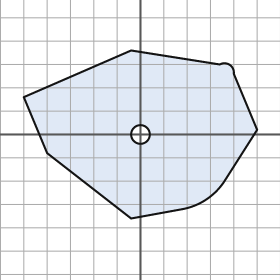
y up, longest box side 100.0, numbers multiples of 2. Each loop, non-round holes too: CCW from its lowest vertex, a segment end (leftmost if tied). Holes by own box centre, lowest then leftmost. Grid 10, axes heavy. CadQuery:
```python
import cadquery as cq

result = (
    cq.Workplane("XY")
    .moveTo(-4.0, -36.0)
    .lineTo(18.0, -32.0)
    .threePointArc((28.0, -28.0), (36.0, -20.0))
    .lineTo(50.0, 2.0)
    .lineTo(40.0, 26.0)
    .threePointArc((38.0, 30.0), (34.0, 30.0))
    .lineTo(-4.0, 36.0)
    .lineTo(-50.0, 16.0)
    .lineTo(-40.0, -8.0)
    .close()
    .moveTo(0.0, 0.0)
    .circle(4.0)
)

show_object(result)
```